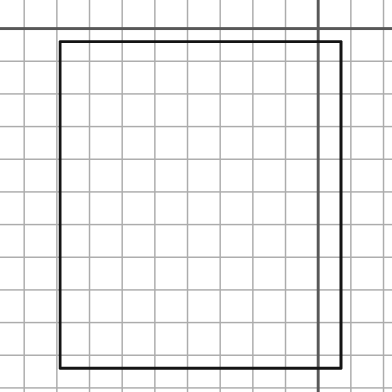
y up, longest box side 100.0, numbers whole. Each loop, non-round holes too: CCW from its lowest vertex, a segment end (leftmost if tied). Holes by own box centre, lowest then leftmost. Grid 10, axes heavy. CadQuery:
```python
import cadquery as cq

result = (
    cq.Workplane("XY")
    .moveTo(-79.0, -104.0)
    .lineTo(7.0, -104.0)
    .lineTo(7.0, -4.0)
    .lineTo(-79.0, -4.0)
    .close()
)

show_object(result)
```